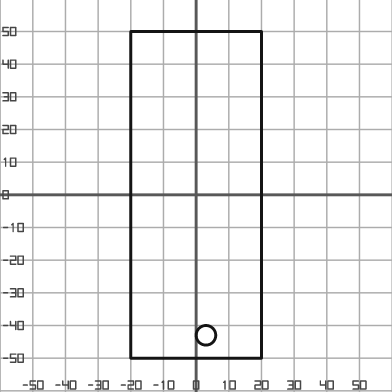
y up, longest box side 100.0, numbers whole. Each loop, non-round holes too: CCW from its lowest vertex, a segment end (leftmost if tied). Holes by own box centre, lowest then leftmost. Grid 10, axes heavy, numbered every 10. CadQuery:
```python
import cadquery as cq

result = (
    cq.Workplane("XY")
    .moveTo(-20.0, -50.0)
    .lineTo(20.0, -50.0)
    .lineTo(20.0, 50.0)
    .lineTo(-20.0, 50.0)
    .close()
    .moveTo(3.0, -43.0)
    .circle(3.0)
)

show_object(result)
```